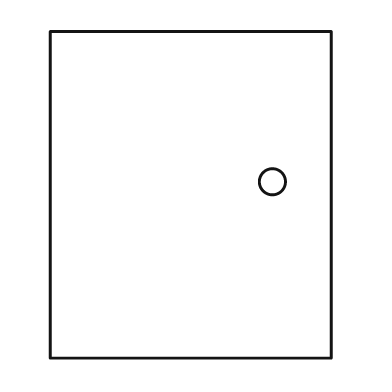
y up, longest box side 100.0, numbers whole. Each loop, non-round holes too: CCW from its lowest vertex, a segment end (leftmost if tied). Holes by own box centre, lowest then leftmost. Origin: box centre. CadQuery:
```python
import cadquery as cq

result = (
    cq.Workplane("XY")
    .moveTo(-43.0, -50.0)
    .lineTo(43.0, -50.0)
    .lineTo(43.0, 50.0)
    .lineTo(-43.0, 50.0)
    .close()
    .moveTo(25.0, 4.0)
    .circle(4.0)
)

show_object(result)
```